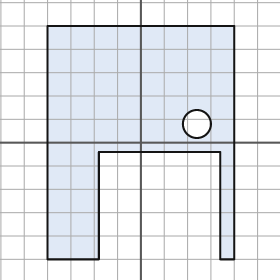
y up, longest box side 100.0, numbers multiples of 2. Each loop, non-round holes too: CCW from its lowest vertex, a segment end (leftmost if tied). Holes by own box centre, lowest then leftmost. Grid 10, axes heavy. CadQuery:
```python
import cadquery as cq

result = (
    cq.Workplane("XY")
    .moveTo(-40.0, -50.0)
    .lineTo(-18.0, -50.0)
    .lineTo(-18.0, -4.0)
    .lineTo(34.0, -4.0)
    .lineTo(34.0, -50.0)
    .lineTo(40.0, -50.0)
    .lineTo(40.0, 50.0)
    .lineTo(-40.0, 50.0)
    .close()
    .moveTo(24.0, 8.0)
    .circle(6.0)
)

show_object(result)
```